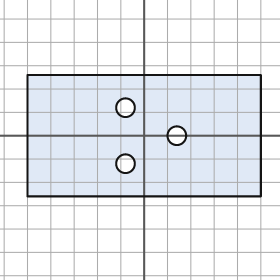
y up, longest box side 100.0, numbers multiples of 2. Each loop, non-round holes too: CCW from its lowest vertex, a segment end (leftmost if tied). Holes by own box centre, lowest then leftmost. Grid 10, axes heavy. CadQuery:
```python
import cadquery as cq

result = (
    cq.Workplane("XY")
    .moveTo(-50.0, -26.0)
    .lineTo(50.0, -26.0)
    .lineTo(50.0, 26.0)
    .lineTo(-50.0, 26.0)
    .close()
    .moveTo(-8.0, -12.0)
    .circle(4.0)
    .moveTo(14.0, 0.0)
    .circle(4.0)
    .moveTo(-8.0, 12.0)
    .circle(4.0)
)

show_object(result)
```